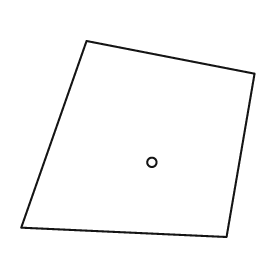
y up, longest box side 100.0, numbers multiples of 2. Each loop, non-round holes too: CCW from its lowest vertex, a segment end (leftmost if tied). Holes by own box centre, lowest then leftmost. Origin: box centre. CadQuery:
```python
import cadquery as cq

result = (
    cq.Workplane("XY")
    .moveTo(38.0, -42.0)
    .lineTo(50.0, 28.0)
    .lineTo(-22.0, 42.0)
    .lineTo(-50.0, -38.0)
    .close()
    .moveTo(6.0, -10.0)
    .circle(2.0)
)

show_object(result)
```